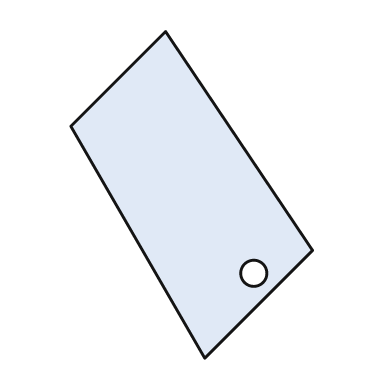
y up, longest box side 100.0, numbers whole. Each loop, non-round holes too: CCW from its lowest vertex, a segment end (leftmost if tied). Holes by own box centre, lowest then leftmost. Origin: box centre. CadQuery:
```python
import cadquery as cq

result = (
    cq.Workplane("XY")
    .moveTo(4.0, -50.0)
    .lineTo(37.0, -17.0)
    .lineTo(-8.0, 50.0)
    .lineTo(-37.0, 21.0)
    .close()
    .moveTo(19.0, -24.0)
    .circle(4.0)
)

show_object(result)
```